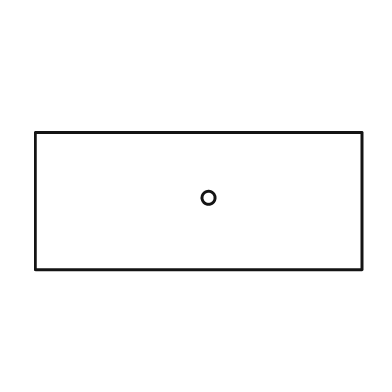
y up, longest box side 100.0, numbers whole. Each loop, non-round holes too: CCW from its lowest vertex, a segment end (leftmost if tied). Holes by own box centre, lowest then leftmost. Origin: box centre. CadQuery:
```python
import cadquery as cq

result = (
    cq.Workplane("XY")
    .moveTo(-50.0, -21.0)
    .lineTo(50.0, -21.0)
    .lineTo(50.0, 21.0)
    .lineTo(-50.0, 21.0)
    .close()
    .moveTo(3.0, 1.0)
    .circle(2.0)
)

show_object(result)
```